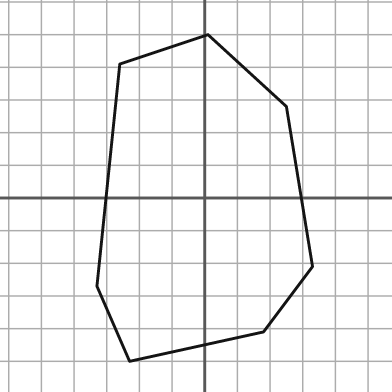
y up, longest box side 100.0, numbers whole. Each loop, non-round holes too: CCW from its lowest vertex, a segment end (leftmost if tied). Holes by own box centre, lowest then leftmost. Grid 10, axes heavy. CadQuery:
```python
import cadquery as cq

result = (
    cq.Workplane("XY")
    .moveTo(-23.0, -50.0)
    .lineTo(18.0, -41.0)
    .lineTo(33.0, -21.0)
    .lineTo(25.0, 28.0)
    .lineTo(1.0, 50.0)
    .lineTo(-26.0, 41.0)
    .lineTo(-33.0, -27.0)
    .close()
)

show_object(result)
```